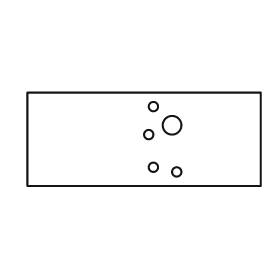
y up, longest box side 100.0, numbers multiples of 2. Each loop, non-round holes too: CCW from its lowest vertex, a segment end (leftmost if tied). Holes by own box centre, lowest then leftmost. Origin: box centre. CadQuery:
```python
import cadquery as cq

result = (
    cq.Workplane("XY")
    .moveTo(-50.0, -20.0)
    .lineTo(50.0, -20.0)
    .lineTo(50.0, 20.0)
    .lineTo(-50.0, 20.0)
    .close()
    .moveTo(14.0, -14.0)
    .circle(2.0)
    .moveTo(4.0, -12.0)
    .circle(2.0)
    .moveTo(2.0, 2.0)
    .circle(2.0)
    .moveTo(12.0, 6.0)
    .circle(4.0)
    .moveTo(4.0, 14.0)
    .circle(2.0)
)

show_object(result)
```